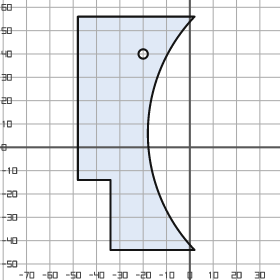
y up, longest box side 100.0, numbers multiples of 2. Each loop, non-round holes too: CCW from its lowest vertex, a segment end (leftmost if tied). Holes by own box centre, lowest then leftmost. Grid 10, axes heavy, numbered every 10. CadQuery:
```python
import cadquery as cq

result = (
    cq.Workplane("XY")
    .moveTo(-34.0, -44.0)
    .lineTo(2.0, -44.0)
    .threePointArc((-18.0, 6.0), (2.0, 56.0))
    .lineTo(-48.0, 56.0)
    .lineTo(-48.0, -14.0)
    .lineTo(-34.0, -14.0)
    .close()
    .moveTo(-20.0, 40.0)
    .circle(2.0)
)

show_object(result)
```